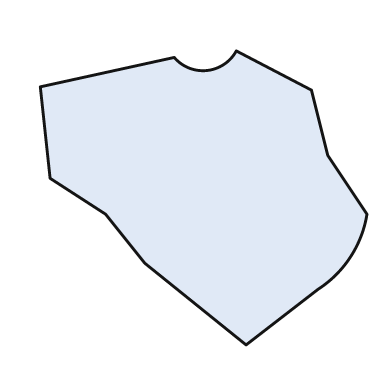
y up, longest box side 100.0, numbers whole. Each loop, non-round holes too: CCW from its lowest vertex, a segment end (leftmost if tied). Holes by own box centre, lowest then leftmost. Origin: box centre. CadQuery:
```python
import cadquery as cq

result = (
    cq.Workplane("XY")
    .moveTo(13.0, -45.0)
    .lineTo(35.0, -28.0)
    .threePointArc((45.0, -18.0), (50.0, -5.0))
    .lineTo(38.0, 13.0)
    .lineTo(33.0, 33.0)
    .lineTo(10.0, 45.0)
    .threePointArc((1.0, 39.0), (-9.0, 43.0))
    .lineTo(-50.0, 34.0)
    .lineTo(-47.0, 6.0)
    .lineTo(-30.0, -5.0)
    .lineTo(-18.0, -20.0)
    .close()
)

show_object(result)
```